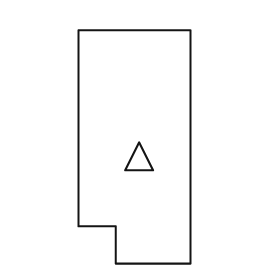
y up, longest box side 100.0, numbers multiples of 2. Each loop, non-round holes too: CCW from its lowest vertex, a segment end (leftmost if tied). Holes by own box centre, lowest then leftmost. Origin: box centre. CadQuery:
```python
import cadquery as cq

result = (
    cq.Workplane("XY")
    .moveTo(-8.0, -50.0)
    .lineTo(24.0, -50.0)
    .lineTo(24.0, 50.0)
    .lineTo(-24.0, 50.0)
    .lineTo(-24.0, -34.0)
    .lineTo(-8.0, -34.0)
    .close()
    .moveTo(-4.0, -10.0)
    .lineTo(8.0, -10.0)
    .lineTo(2.0, 2.0)
    .close()
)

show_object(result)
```